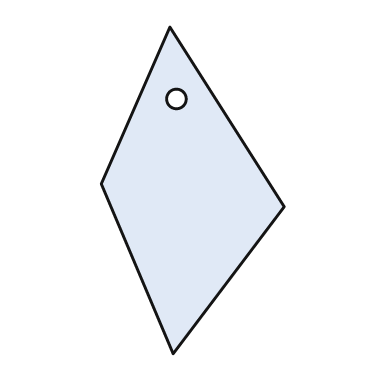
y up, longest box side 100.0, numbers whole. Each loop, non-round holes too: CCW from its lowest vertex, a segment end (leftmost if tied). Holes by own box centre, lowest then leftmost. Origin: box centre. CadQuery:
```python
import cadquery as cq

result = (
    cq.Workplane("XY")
    .moveTo(-6.0, -50.0)
    .lineTo(28.0, -5.0)
    .lineTo(-7.0, 50.0)
    .lineTo(-28.0, 2.0)
    .close()
    .moveTo(-5.0, 28.0)
    .circle(3.0)
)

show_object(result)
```